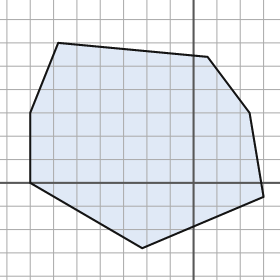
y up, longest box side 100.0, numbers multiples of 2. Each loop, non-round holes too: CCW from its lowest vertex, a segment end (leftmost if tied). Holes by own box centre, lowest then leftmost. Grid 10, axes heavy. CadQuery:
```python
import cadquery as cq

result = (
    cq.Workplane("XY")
    .moveTo(-22.0, -28.0)
    .lineTo(30.0, -6.0)
    .lineTo(24.0, 30.0)
    .lineTo(6.0, 54.0)
    .lineTo(-58.0, 60.0)
    .lineTo(-70.0, 30.0)
    .lineTo(-70.0, 0.0)
    .close()
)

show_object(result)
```